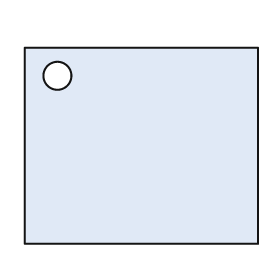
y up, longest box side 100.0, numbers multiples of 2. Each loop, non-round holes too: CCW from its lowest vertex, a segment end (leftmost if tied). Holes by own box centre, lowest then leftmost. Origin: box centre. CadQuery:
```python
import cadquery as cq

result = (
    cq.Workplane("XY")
    .moveTo(-50.0, -42.0)
    .lineTo(50.0, -42.0)
    .lineTo(50.0, 42.0)
    .lineTo(-50.0, 42.0)
    .close()
    .moveTo(-36.0, 30.0)
    .circle(6.0)
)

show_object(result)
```